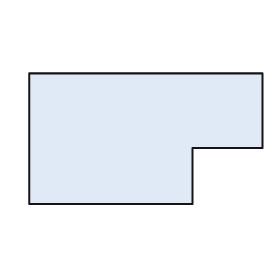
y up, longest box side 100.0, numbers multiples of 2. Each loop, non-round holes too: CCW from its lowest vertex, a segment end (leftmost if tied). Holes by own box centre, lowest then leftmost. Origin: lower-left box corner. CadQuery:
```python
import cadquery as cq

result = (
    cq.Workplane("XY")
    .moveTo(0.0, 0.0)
    .lineTo(70.0, 0.0)
    .lineTo(70.0, 24.0)
    .lineTo(100.0, 24.0)
    .lineTo(100.0, 56.0)
    .lineTo(0.0, 56.0)
    .close()
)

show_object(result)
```